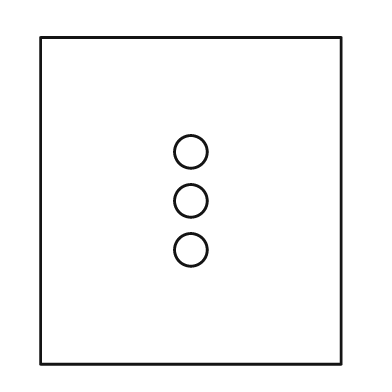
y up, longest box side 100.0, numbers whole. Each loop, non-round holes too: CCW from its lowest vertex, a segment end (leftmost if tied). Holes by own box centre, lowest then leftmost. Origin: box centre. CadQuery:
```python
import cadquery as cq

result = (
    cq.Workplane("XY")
    .moveTo(-46.0, -50.0)
    .lineTo(46.0, -50.0)
    .lineTo(46.0, 50.0)
    .lineTo(-46.0, 50.0)
    .close()
    .moveTo(0.0, -15.0)
    .circle(5.0)
    .moveTo(0.0, 0.0)
    .circle(5.0)
    .moveTo(0.0, 15.0)
    .circle(5.0)
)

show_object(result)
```